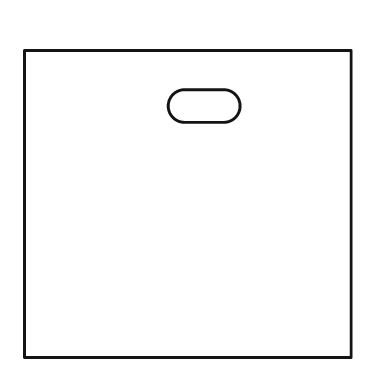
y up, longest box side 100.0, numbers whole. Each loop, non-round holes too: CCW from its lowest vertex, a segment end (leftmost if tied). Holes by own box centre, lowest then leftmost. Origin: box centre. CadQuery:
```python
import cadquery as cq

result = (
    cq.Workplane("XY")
    .moveTo(-50.0, -47.0)
    .lineTo(50.0, -47.0)
    .lineTo(50.0, 47.0)
    .lineTo(-50.0, 47.0)
    .close()
    .moveTo(-1.0, 25.0)
    .lineTo(11.0, 25.0)
    .threePointArc((16.0, 30.0), (11.0, 35.0))
    .lineTo(-1.0, 35.0)
    .threePointArc((-6.0, 30.0), (-1.0, 25.0))
    .close()
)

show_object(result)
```